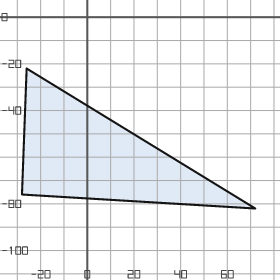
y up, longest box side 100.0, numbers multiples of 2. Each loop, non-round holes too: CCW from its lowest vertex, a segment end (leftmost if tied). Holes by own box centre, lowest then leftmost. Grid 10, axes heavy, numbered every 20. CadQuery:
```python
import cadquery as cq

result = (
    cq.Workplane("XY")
    .moveTo(72.0, -82.0)
    .lineTo(-26.0, -22.0)
    .lineTo(-28.0, -76.0)
    .close()
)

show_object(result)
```